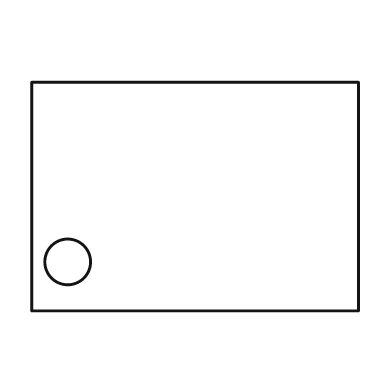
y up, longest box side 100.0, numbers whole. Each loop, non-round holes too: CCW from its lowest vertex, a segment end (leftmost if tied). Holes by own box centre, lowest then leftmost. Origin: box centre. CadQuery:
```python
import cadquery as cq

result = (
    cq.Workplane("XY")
    .moveTo(-50.0, -35.0)
    .lineTo(50.0, -35.0)
    .lineTo(50.0, 35.0)
    .lineTo(-50.0, 35.0)
    .close()
    .moveTo(-39.0, -20.0)
    .circle(7.0)
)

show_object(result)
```